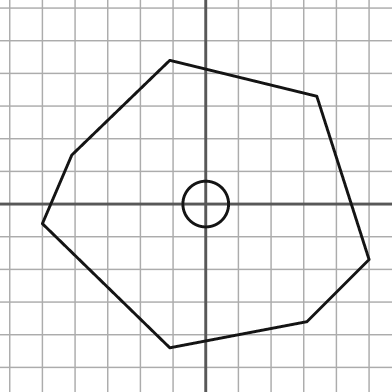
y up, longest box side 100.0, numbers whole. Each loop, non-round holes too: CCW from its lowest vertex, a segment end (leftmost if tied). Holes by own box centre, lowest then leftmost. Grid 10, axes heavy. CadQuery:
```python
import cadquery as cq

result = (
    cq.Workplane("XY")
    .moveTo(-11.0, -44.0)
    .lineTo(31.0, -36.0)
    .lineTo(50.0, -17.0)
    .lineTo(34.0, 33.0)
    .lineTo(-11.0, 44.0)
    .lineTo(-41.0, 15.0)
    .lineTo(-50.0, -6.0)
    .close()
    .moveTo(0.0, 0.0)
    .circle(7.0)
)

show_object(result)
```